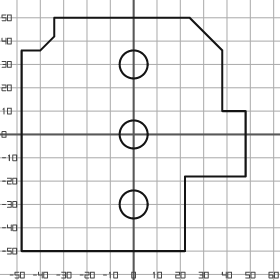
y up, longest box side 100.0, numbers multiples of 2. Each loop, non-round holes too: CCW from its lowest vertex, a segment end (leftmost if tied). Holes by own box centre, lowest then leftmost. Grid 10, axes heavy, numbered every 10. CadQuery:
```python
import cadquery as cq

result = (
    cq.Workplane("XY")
    .moveTo(-48.0, -50.0)
    .lineTo(22.0, -50.0)
    .lineTo(22.0, -18.0)
    .lineTo(48.0, -18.0)
    .lineTo(48.0, 10.0)
    .lineTo(38.0, 10.0)
    .lineTo(38.0, 36.0)
    .lineTo(24.0, 50.0)
    .lineTo(-34.0, 50.0)
    .lineTo(-34.0, 42.0)
    .lineTo(-40.0, 36.0)
    .lineTo(-48.0, 36.0)
    .close()
    .moveTo(0.0, -30.0)
    .circle(6.0)
    .moveTo(0.0, 0.0)
    .circle(6.0)
    .moveTo(0.0, 30.0)
    .circle(6.0)
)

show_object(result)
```